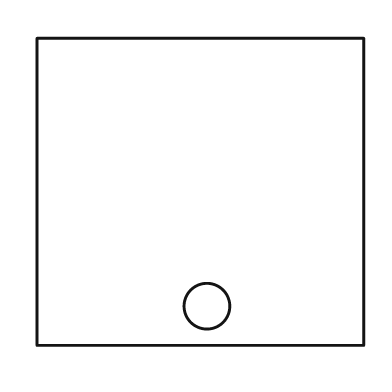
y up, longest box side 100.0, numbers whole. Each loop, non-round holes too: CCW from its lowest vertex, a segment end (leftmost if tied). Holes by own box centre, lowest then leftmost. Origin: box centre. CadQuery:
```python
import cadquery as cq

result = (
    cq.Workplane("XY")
    .moveTo(-50.0, -47.0)
    .lineTo(50.0, -47.0)
    .lineTo(50.0, 47.0)
    .lineTo(-50.0, 47.0)
    .close()
    .moveTo(2.0, -35.0)
    .circle(7.0)
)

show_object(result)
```